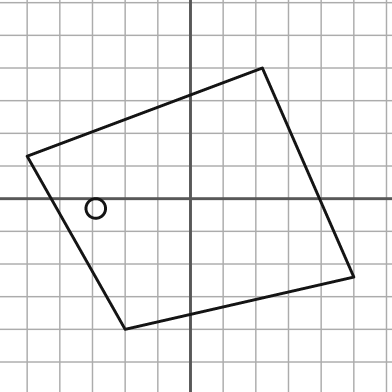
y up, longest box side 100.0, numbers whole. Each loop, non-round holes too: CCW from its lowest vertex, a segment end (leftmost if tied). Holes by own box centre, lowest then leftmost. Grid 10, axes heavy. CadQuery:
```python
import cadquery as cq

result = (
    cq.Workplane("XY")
    .moveTo(-20.0, -40.0)
    .lineTo(50.0, -24.0)
    .lineTo(22.0, 40.0)
    .lineTo(-50.0, 13.0)
    .close()
    .moveTo(-29.0, -3.0)
    .circle(3.0)
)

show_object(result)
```